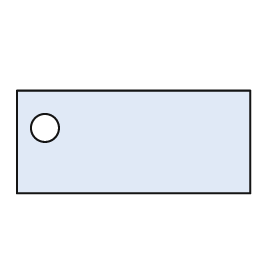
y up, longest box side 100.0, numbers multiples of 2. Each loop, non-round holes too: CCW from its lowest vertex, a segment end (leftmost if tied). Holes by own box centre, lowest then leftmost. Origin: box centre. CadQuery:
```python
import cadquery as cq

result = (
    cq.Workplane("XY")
    .moveTo(-50.0, -22.0)
    .lineTo(50.0, -22.0)
    .lineTo(50.0, 22.0)
    .lineTo(-50.0, 22.0)
    .close()
    .moveTo(-38.0, 6.0)
    .circle(6.0)
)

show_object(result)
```